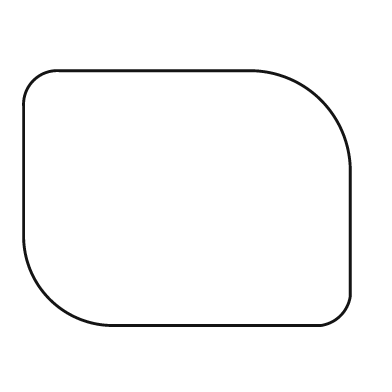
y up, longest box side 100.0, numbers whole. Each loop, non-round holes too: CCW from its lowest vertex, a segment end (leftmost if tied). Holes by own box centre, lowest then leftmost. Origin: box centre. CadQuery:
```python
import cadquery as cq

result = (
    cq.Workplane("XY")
    .moveTo(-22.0, -39.0)
    .lineTo(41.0, -39.0)
    .threePointArc((47.0, -36.0), (50.0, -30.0))
    .lineTo(50.0, 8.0)
    .threePointArc((41.0, 30.0), (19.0, 39.0))
    .lineTo(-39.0, 39.0)
    .threePointArc((-47.0, 36.0), (-50.0, 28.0))
    .lineTo(-50.0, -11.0)
    .threePointArc((-42.0, -31.0), (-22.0, -39.0))
    .close()
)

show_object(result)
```